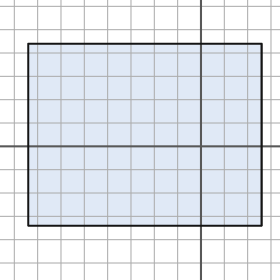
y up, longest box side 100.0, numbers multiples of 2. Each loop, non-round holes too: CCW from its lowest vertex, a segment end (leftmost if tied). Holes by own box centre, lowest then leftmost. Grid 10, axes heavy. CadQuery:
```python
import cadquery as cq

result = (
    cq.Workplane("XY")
    .moveTo(-74.0, -34.0)
    .lineTo(26.0, -34.0)
    .lineTo(26.0, 44.0)
    .lineTo(-74.0, 44.0)
    .close()
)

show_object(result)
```